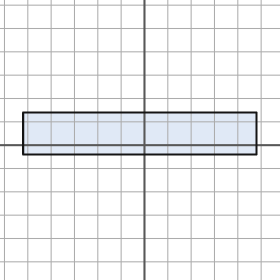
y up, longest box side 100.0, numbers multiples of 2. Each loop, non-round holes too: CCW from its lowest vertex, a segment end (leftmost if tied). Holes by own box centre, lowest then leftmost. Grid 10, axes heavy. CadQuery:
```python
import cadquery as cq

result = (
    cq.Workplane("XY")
    .moveTo(-52.0, -4.0)
    .lineTo(48.0, -4.0)
    .lineTo(48.0, 14.0)
    .lineTo(-52.0, 14.0)
    .close()
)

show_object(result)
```